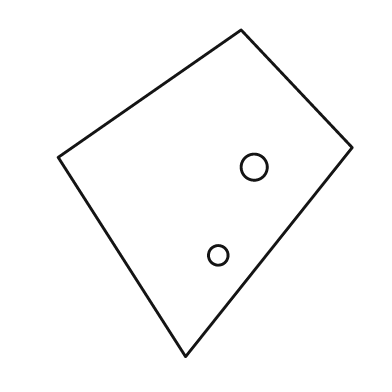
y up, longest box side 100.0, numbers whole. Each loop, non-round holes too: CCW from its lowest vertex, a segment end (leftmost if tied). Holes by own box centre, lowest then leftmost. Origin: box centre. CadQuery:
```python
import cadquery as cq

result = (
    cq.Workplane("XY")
    .moveTo(-6.0, -50.0)
    .lineTo(45.0, 14.0)
    .lineTo(11.0, 50.0)
    .lineTo(-45.0, 11.0)
    .close()
    .moveTo(4.0, -19.0)
    .circle(3.0)
    .moveTo(15.0, 8.0)
    .circle(4.0)
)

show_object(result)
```